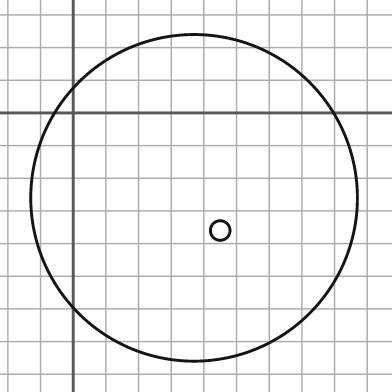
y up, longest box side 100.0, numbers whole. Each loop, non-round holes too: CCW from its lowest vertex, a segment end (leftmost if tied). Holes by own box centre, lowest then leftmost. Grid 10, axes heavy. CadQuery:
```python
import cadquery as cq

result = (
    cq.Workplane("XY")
    .moveTo(37.0, -26.0)
    .circle(50.0)
    .moveTo(45.0, -36.0)
    .circle(3.0)
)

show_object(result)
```